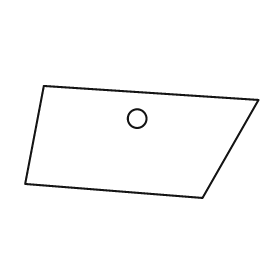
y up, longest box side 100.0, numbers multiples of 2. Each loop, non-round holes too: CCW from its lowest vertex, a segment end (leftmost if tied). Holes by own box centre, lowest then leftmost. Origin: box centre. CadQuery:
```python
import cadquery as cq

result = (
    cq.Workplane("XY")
    .moveTo(26.0, -24.0)
    .lineTo(50.0, 18.0)
    .lineTo(-42.0, 24.0)
    .lineTo(-50.0, -18.0)
    .close()
    .moveTo(-2.0, 10.0)
    .circle(4.0)
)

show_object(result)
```